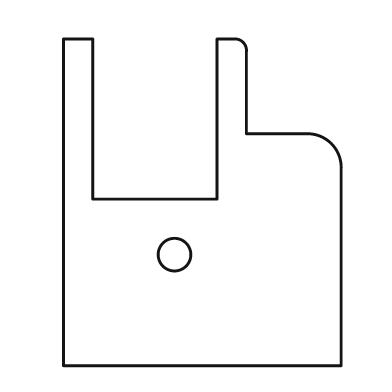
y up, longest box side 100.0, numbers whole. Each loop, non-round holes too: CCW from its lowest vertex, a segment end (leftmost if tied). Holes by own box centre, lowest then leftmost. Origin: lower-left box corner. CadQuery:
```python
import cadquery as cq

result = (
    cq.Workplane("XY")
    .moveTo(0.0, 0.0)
    .lineTo(85.0, 0.0)
    .lineTo(85.0, 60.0)
    .threePointArc((82.0, 68.0), (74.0, 71.0))
    .lineTo(56.0, 71.0)
    .lineTo(56.0, 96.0)
    .threePointArc((55.0, 99.0), (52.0, 100.0))
    .lineTo(47.0, 100.0)
    .lineTo(47.0, 51.0)
    .lineTo(9.0, 51.0)
    .lineTo(9.0, 100.0)
    .lineTo(0.0, 100.0)
    .close()
    .moveTo(34.0, 34.0)
    .circle(5.0)
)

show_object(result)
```